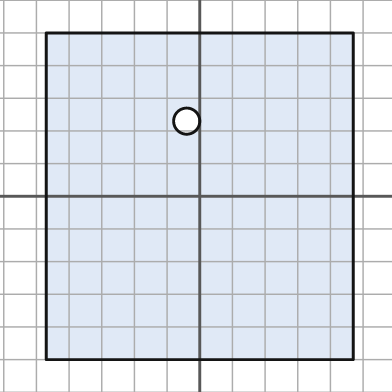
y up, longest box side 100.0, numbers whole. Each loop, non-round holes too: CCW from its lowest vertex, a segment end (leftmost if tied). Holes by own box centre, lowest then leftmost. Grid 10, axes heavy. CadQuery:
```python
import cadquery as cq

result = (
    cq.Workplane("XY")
    .moveTo(-47.0, -50.0)
    .lineTo(47.0, -50.0)
    .lineTo(47.0, 50.0)
    .lineTo(-47.0, 50.0)
    .close()
    .moveTo(-4.0, 23.0)
    .circle(4.0)
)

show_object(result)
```